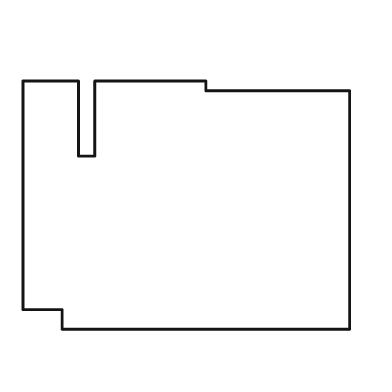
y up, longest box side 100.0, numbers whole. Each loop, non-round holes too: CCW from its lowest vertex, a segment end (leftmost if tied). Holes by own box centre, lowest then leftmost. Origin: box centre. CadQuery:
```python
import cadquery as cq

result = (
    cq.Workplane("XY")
    .moveTo(-38.0, -38.0)
    .lineTo(50.0, -38.0)
    .lineTo(50.0, 35.0)
    .lineTo(6.0, 35.0)
    .lineTo(6.0, 38.0)
    .lineTo(-28.0, 38.0)
    .lineTo(-28.0, 15.0)
    .lineTo(-33.0, 15.0)
    .lineTo(-33.0, 38.0)
    .lineTo(-50.0, 38.0)
    .lineTo(-50.0, -32.0)
    .lineTo(-38.0, -32.0)
    .close()
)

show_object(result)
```